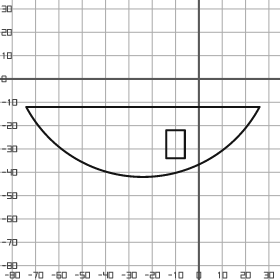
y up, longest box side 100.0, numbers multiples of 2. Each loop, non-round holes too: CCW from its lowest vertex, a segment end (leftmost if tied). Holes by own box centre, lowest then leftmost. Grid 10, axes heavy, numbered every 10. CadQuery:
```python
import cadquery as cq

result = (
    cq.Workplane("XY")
    .moveTo(-74.0, -12.0)
    .threePointArc((-24.0, -42.0), (26.0, -12.0))
    .close()
    .moveTo(-14.0, -34.0)
    .lineTo(-6.0, -34.0)
    .lineTo(-6.0, -22.0)
    .lineTo(-14.0, -22.0)
    .close()
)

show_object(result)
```